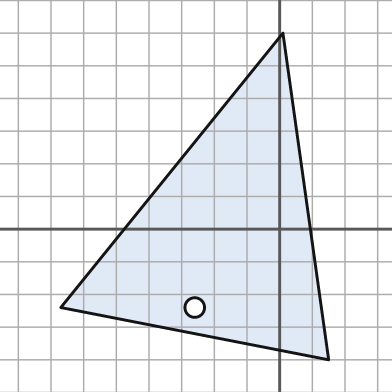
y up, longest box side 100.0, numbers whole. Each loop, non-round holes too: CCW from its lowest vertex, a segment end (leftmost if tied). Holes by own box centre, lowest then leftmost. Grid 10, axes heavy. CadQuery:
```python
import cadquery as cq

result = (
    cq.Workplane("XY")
    .moveTo(15.0, -40.0)
    .lineTo(1.0, 60.0)
    .lineTo(-67.0, -24.0)
    .close()
    .moveTo(-26.0, -24.0)
    .circle(3.0)
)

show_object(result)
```